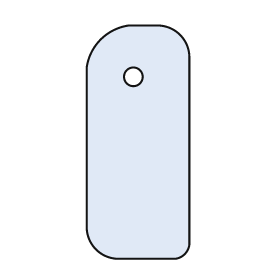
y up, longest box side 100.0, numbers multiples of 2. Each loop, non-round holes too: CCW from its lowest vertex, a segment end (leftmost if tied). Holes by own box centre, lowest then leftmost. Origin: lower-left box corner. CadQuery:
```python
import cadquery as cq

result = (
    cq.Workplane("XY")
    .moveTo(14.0, 0.0)
    .lineTo(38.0, 0.0)
    .threePointArc((42.0, 2.0), (44.0, 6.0))
    .lineTo(44.0, 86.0)
    .threePointArc((40.0, 96.0), (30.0, 100.0))
    .lineTo(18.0, 100.0)
    .threePointArc((6.0, 94.0), (0.0, 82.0))
    .lineTo(0.0, 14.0)
    .threePointArc((4.0, 4.0), (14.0, 0.0))
    .close()
    .moveTo(20.0, 78.0)
    .circle(4.0)
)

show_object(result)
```